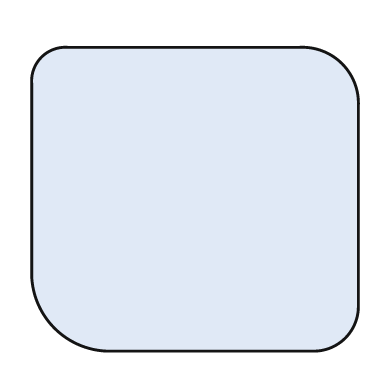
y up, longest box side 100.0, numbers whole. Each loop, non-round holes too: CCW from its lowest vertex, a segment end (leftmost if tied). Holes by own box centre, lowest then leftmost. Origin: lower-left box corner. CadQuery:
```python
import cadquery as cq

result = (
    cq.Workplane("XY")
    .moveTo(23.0, 0.0)
    .lineTo(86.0, 0.0)
    .threePointArc((96.0, 4.0), (100.0, 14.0))
    .lineTo(100.0, 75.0)
    .threePointArc((95.0, 88.0), (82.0, 93.0))
    .lineTo(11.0, 93.0)
    .threePointArc((3.0, 90.0), (0.0, 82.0))
    .lineTo(0.0, 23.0)
    .threePointArc((7.0, 7.0), (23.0, 0.0))
    .close()
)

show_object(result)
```